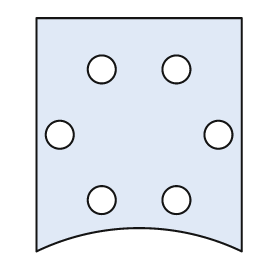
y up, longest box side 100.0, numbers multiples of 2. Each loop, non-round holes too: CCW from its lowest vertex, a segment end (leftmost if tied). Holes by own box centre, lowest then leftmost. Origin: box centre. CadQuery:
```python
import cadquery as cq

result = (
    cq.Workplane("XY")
    .moveTo(-44.0, -50.0)
    .threePointArc((0.0, -40.0), (44.0, -50.0))
    .lineTo(44.0, 50.0)
    .lineTo(-44.0, 50.0)
    .close()
    .moveTo(-16.0, -28.0)
    .circle(6.0)
    .moveTo(16.0, -28.0)
    .circle(6.0)
    .moveTo(-34.0, 0.0)
    .circle(6.0)
    .moveTo(34.0, 0.0)
    .circle(6.0)
    .moveTo(-16.0, 28.0)
    .circle(6.0)
    .moveTo(16.0, 28.0)
    .circle(6.0)
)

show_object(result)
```